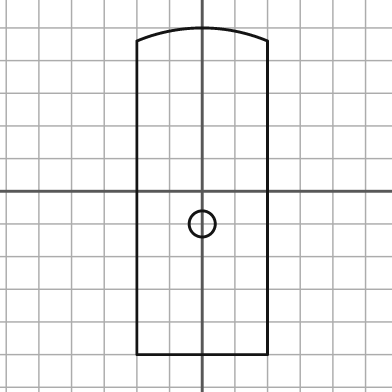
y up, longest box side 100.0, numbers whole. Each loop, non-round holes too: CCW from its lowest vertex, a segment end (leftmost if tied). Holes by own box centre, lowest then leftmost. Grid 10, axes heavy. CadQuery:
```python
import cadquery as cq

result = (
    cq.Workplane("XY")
    .moveTo(-20.0, -50.0)
    .lineTo(20.0, -50.0)
    .lineTo(20.0, 46.0)
    .threePointArc((0.0, 50.0), (-20.0, 46.0))
    .close()
    .moveTo(0.0, -10.0)
    .circle(4.0)
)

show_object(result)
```